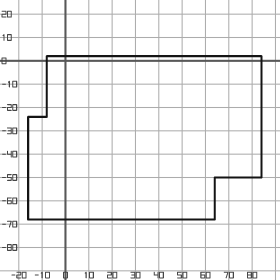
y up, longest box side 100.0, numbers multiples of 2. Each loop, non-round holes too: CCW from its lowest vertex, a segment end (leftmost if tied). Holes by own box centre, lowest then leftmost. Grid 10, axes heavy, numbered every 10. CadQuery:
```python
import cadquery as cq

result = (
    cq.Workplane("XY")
    .moveTo(-16.0, -68.0)
    .lineTo(64.0, -68.0)
    .lineTo(64.0, -50.0)
    .lineTo(84.0, -50.0)
    .lineTo(84.0, 2.0)
    .lineTo(-8.0, 2.0)
    .lineTo(-8.0, -24.0)
    .lineTo(-16.0, -24.0)
    .close()
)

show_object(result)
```